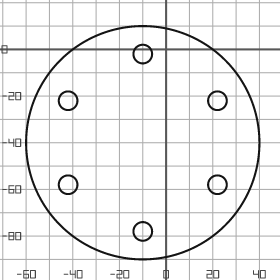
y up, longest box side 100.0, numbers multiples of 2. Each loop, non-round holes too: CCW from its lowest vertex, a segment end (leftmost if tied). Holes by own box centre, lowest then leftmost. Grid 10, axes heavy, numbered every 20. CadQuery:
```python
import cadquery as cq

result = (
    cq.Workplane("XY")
    .moveTo(-10.0, -40.0)
    .circle(50.0)
    .moveTo(-10.0, -78.0)
    .circle(4.0)
    .moveTo(-42.0, -58.0)
    .circle(4.0)
    .moveTo(22.0, -58.0)
    .circle(4.0)
    .moveTo(-42.0, -22.0)
    .circle(4.0)
    .moveTo(22.0, -22.0)
    .circle(4.0)
    .moveTo(-10.0, -2.0)
    .circle(4.0)
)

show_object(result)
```